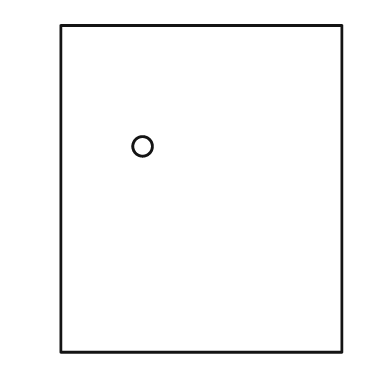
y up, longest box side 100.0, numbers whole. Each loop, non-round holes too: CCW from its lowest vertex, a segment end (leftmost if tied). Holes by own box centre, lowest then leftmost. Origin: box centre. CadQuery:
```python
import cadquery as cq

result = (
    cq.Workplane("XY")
    .moveTo(-43.0, -50.0)
    .lineTo(43.0, -50.0)
    .lineTo(43.0, 50.0)
    .lineTo(-43.0, 50.0)
    .close()
    .moveTo(-18.0, 13.0)
    .circle(3.0)
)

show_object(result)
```